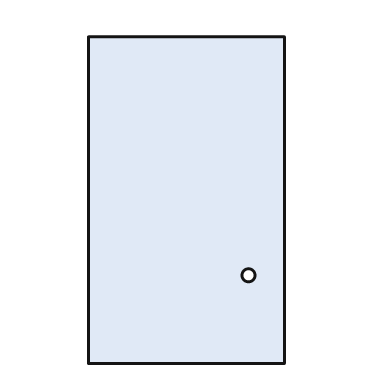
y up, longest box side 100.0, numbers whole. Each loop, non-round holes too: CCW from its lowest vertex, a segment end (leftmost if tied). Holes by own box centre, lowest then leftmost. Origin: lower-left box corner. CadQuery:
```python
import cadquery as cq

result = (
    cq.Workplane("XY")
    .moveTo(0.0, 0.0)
    .lineTo(60.0, 0.0)
    .lineTo(60.0, 100.0)
    .lineTo(0.0, 100.0)
    .close()
    .moveTo(49.0, 27.0)
    .circle(2.0)
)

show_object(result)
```